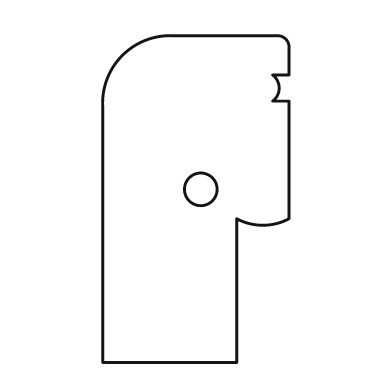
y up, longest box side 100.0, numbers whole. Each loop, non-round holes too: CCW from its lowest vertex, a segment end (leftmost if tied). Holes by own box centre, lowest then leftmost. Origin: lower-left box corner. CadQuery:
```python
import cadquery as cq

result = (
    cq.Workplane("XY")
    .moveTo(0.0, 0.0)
    .lineTo(41.0, 0.0)
    .lineTo(41.0, 44.0)
    .threePointArc((49.0, 42.0), (57.0, 44.0))
    .lineTo(57.0, 80.0)
    .lineTo(52.0, 80.0)
    .threePointArc((54.0, 84.0), (52.0, 88.0))
    .lineTo(57.0, 88.0)
    .lineTo(57.0, 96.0)
    .threePointArc((56.0, 99.0), (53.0, 100.0))
    .lineTo(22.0, 100.0)
    .threePointArc((6.0, 94.0), (0.0, 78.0))
    .close()
    .moveTo(30.0, 53.0)
    .circle(5.0)
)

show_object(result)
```